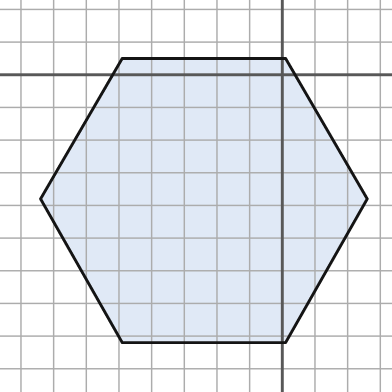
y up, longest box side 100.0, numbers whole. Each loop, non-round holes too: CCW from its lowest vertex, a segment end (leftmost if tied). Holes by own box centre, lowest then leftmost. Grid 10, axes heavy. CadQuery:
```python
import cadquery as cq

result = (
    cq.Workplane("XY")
    .moveTo(-49.0, -82.0)
    .lineTo(1.0, -82.0)
    .lineTo(26.0, -38.0)
    .lineTo(1.0, 5.0)
    .lineTo(-49.0, 5.0)
    .lineTo(-74.0, -38.0)
    .close()
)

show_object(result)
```